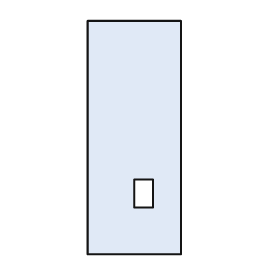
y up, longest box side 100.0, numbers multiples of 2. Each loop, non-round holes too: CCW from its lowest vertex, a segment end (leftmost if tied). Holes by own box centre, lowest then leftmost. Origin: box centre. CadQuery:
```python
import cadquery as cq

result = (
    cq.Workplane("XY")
    .moveTo(-20.0, -50.0)
    .lineTo(20.0, -50.0)
    .lineTo(20.0, 50.0)
    .lineTo(-20.0, 50.0)
    .close()
    .moveTo(0.0, -30.0)
    .lineTo(8.0, -30.0)
    .lineTo(8.0, -18.0)
    .lineTo(0.0, -18.0)
    .close()
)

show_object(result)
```